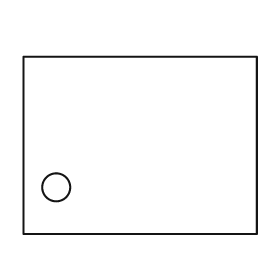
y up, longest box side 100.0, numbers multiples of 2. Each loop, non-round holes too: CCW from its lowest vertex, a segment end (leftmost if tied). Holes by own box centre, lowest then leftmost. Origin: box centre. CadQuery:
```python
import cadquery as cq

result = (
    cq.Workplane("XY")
    .moveTo(-50.0, -38.0)
    .lineTo(50.0, -38.0)
    .lineTo(50.0, 38.0)
    .lineTo(-50.0, 38.0)
    .close()
    .moveTo(-36.0, -18.0)
    .circle(6.0)
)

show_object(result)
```